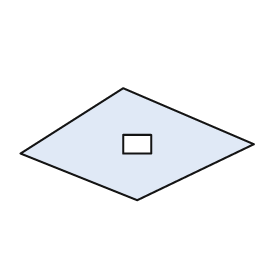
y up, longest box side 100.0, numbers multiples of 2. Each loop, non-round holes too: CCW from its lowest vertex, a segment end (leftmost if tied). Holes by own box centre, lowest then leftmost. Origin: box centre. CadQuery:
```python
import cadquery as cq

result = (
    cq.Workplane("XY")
    .moveTo(0.0, -24.0)
    .lineTo(50.0, 0.0)
    .lineTo(-6.0, 24.0)
    .lineTo(-50.0, -4.0)
    .close()
    .moveTo(-6.0, -4.0)
    .lineTo(6.0, -4.0)
    .lineTo(6.0, 4.0)
    .lineTo(-6.0, 4.0)
    .close()
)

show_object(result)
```